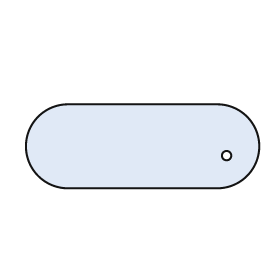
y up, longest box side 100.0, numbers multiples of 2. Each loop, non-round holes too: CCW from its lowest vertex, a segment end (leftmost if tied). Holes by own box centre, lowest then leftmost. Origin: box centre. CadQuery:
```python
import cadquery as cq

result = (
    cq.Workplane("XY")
    .moveTo(-32.0, -18.0)
    .lineTo(32.0, -18.0)
    .threePointArc((50.0, 0.0), (32.0, 18.0))
    .lineTo(-32.0, 18.0)
    .threePointArc((-50.0, 0.0), (-32.0, -18.0))
    .close()
    .moveTo(36.0, -4.0)
    .circle(2.0)
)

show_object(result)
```